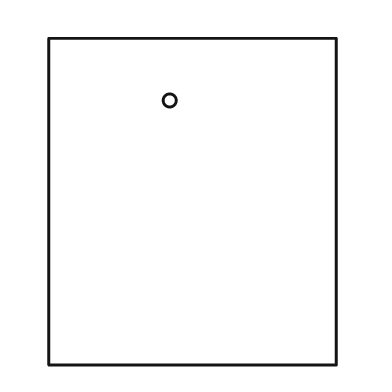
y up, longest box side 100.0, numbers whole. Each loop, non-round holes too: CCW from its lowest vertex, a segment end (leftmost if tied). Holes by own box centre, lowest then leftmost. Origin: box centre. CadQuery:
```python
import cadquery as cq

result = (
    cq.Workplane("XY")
    .moveTo(-44.0, -50.0)
    .lineTo(44.0, -50.0)
    .lineTo(44.0, 50.0)
    .lineTo(-44.0, 50.0)
    .close()
    .moveTo(-7.0, 31.0)
    .circle(2.0)
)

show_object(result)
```